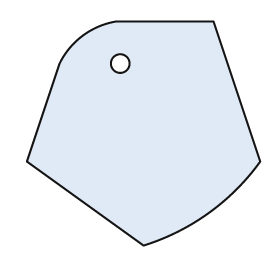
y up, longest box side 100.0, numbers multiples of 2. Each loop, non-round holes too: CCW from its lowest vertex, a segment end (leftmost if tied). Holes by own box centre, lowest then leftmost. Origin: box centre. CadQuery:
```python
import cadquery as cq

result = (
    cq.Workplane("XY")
    .moveTo(0.0, -48.0)
    .threePointArc((28.0, -34.0), (50.0, -12.0))
    .lineTo(30.0, 48.0)
    .lineTo(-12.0, 48.0)
    .threePointArc((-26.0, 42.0), (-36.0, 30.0))
    .lineTo(-50.0, -12.0)
    .close()
    .moveTo(-10.0, 30.0)
    .circle(4.0)
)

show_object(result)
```